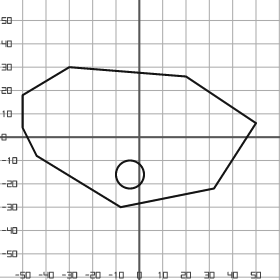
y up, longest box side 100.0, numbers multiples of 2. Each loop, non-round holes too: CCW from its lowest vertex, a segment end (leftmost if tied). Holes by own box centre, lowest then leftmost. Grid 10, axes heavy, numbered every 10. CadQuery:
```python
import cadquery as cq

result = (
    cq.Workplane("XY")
    .moveTo(-8.0, -30.0)
    .lineTo(32.0, -22.0)
    .lineTo(50.0, 6.0)
    .lineTo(20.0, 26.0)
    .lineTo(-30.0, 30.0)
    .lineTo(-50.0, 18.0)
    .lineTo(-50.0, 4.0)
    .lineTo(-44.0, -8.0)
    .close()
    .moveTo(-4.0, -16.0)
    .circle(6.0)
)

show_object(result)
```